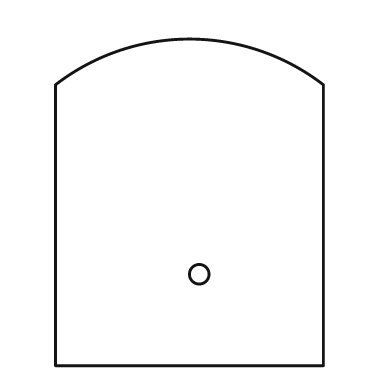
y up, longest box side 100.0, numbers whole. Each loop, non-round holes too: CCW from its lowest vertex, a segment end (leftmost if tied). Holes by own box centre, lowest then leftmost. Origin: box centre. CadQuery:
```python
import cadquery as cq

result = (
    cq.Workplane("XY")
    .moveTo(-41.0, -50.0)
    .lineTo(41.0, -50.0)
    .lineTo(41.0, 36.0)
    .threePointArc((0.0, 50.0), (-41.0, 36.0))
    .close()
    .moveTo(3.0, -22.0)
    .circle(3.0)
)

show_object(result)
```